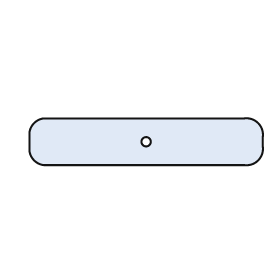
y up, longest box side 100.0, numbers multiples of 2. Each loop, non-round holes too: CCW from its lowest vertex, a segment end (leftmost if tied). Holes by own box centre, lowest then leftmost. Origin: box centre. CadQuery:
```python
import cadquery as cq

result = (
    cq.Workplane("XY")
    .moveTo(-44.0, -10.0)
    .lineTo(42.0, -10.0)
    .threePointArc((48.0, -8.0), (50.0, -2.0))
    .lineTo(50.0, 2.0)
    .threePointArc((48.0, 8.0), (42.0, 10.0))
    .lineTo(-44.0, 10.0)
    .threePointArc((-48.0, 8.0), (-50.0, 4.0))
    .lineTo(-50.0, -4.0)
    .threePointArc((-48.0, -8.0), (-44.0, -10.0))
    .close()
    .moveTo(0.0, 0.0)
    .circle(2.0)
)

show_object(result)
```